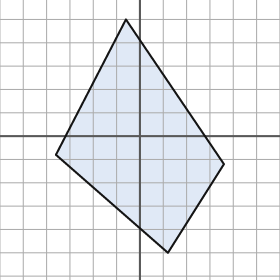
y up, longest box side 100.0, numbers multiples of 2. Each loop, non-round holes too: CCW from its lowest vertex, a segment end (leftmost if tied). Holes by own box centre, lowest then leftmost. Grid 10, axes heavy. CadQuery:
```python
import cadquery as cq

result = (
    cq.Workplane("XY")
    .moveTo(12.0, -50.0)
    .lineTo(36.0, -12.0)
    .lineTo(-6.0, 50.0)
    .lineTo(-36.0, -8.0)
    .close()
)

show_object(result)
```